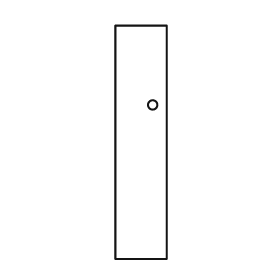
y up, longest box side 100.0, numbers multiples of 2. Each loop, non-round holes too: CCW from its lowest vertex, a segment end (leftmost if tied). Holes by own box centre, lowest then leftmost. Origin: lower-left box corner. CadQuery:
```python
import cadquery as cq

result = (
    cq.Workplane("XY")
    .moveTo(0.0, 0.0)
    .lineTo(22.0, 0.0)
    .lineTo(22.0, 100.0)
    .lineTo(0.0, 100.0)
    .close()
    .moveTo(16.0, 66.0)
    .circle(2.0)
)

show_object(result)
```